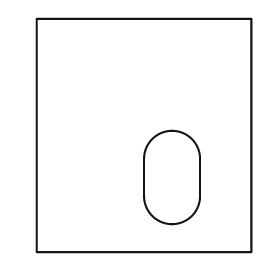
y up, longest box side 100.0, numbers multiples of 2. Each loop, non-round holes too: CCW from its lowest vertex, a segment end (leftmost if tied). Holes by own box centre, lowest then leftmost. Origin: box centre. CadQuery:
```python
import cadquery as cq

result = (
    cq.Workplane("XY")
    .moveTo(-46.0, -50.0)
    .lineTo(46.0, -50.0)
    .lineTo(46.0, 50.0)
    .lineTo(-46.0, 50.0)
    .close()
    .moveTo(0.0, -26.0)
    .threePointArc((12.0, -38.0), (24.0, -26.0))
    .lineTo(24.0, -10.0)
    .threePointArc((12.0, 2.0), (0.0, -10.0))
    .close()
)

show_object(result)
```